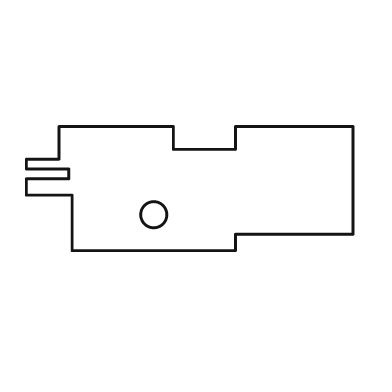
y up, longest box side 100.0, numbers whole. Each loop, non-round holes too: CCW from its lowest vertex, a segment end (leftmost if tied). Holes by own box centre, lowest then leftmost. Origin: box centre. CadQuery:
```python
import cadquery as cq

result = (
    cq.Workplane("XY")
    .moveTo(-36.0, -19.0)
    .lineTo(14.0, -19.0)
    .lineTo(14.0, -14.0)
    .lineTo(50.0, -14.0)
    .lineTo(50.0, 19.0)
    .lineTo(14.0, 19.0)
    .lineTo(14.0, 12.0)
    .lineTo(-5.0, 12.0)
    .lineTo(-5.0, 19.0)
    .lineTo(-40.0, 19.0)
    .lineTo(-40.0, 9.0)
    .lineTo(-50.0, 9.0)
    .lineTo(-50.0, 6.0)
    .lineTo(-37.0, 6.0)
    .lineTo(-37.0, 3.0)
    .lineTo(-50.0, 3.0)
    .lineTo(-50.0, -2.0)
    .lineTo(-36.0, -2.0)
    .close()
    .moveTo(-11.0, -8.0)
    .circle(4.0)
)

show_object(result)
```